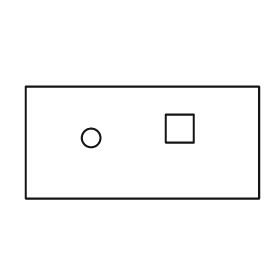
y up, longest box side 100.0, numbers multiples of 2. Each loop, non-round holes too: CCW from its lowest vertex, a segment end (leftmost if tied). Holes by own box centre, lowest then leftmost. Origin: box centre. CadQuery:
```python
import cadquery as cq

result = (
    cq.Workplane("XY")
    .moveTo(-50.0, -24.0)
    .lineTo(50.0, -24.0)
    .lineTo(50.0, 24.0)
    .lineTo(-50.0, 24.0)
    .close()
    .moveTo(-22.0, 2.0)
    .circle(4.0)
    .moveTo(10.0, 0.0)
    .lineTo(22.0, 0.0)
    .lineTo(22.0, 12.0)
    .lineTo(10.0, 12.0)
    .close()
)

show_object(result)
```